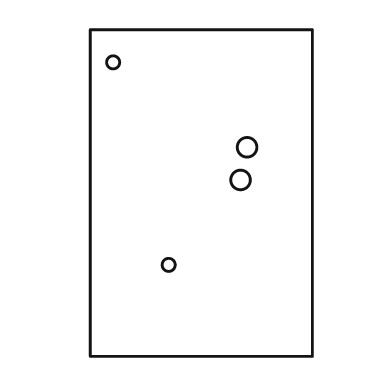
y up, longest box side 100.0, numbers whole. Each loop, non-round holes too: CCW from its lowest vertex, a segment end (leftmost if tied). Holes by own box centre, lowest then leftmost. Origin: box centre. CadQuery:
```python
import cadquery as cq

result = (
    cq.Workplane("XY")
    .moveTo(-34.0, -50.0)
    .lineTo(34.0, -50.0)
    .lineTo(34.0, 50.0)
    .lineTo(-34.0, 50.0)
    .close()
    .moveTo(-10.0, -22.0)
    .circle(2.0)
    .moveTo(12.0, 4.0)
    .circle(3.0)
    .moveTo(14.0, 14.0)
    .circle(3.0)
    .moveTo(-27.0, 40.0)
    .circle(2.0)
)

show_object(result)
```